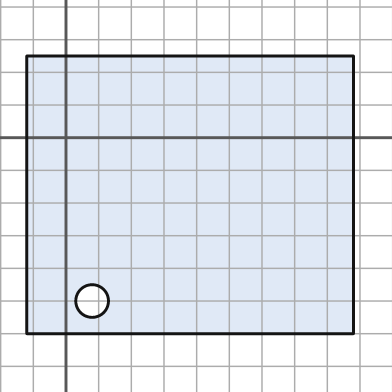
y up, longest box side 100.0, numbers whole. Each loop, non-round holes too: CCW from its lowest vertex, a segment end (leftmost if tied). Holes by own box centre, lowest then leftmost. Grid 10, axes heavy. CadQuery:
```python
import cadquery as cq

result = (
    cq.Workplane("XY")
    .moveTo(-12.0, -60.0)
    .lineTo(88.0, -60.0)
    .lineTo(88.0, 25.0)
    .lineTo(-12.0, 25.0)
    .close()
    .moveTo(8.0, -50.0)
    .circle(5.0)
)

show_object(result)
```